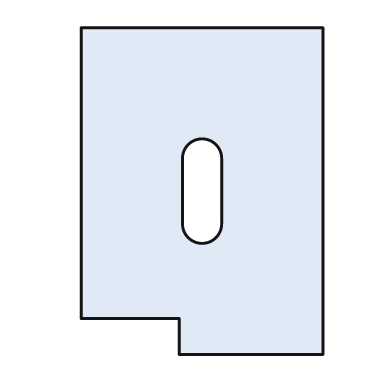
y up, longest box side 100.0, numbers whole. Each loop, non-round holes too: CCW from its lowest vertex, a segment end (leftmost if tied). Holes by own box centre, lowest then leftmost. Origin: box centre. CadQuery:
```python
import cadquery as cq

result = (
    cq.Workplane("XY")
    .moveTo(-7.0, -50.0)
    .lineTo(37.0, -50.0)
    .lineTo(37.0, 50.0)
    .lineTo(-37.0, 50.0)
    .lineTo(-37.0, -39.0)
    .lineTo(-7.0, -39.0)
    .close()
    .moveTo(-6.0, -10.0)
    .threePointArc((0.0, -16.0), (6.0, -10.0))
    .lineTo(6.0, 10.0)
    .threePointArc((0.0, 16.0), (-6.0, 10.0))
    .close()
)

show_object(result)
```